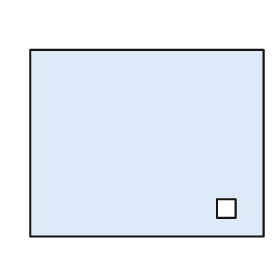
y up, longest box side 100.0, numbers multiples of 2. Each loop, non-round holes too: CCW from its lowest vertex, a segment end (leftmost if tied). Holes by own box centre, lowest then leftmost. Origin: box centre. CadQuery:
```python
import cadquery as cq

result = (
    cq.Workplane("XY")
    .moveTo(-50.0, -40.0)
    .lineTo(50.0, -40.0)
    .lineTo(50.0, 40.0)
    .lineTo(-50.0, 40.0)
    .close()
    .moveTo(30.0, -32.0)
    .lineTo(38.0, -32.0)
    .lineTo(38.0, -24.0)
    .lineTo(30.0, -24.0)
    .close()
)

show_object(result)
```